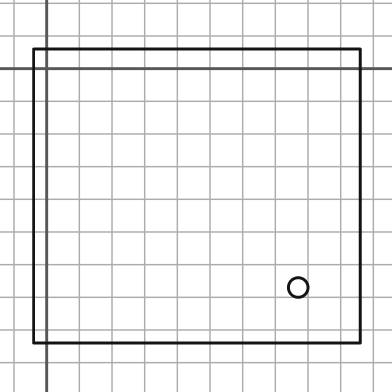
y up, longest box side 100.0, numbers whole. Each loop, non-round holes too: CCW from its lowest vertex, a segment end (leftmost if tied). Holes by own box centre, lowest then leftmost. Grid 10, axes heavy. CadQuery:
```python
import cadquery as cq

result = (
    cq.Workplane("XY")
    .moveTo(-4.0, -84.0)
    .lineTo(96.0, -84.0)
    .lineTo(96.0, 6.0)
    .lineTo(-4.0, 6.0)
    .close()
    .moveTo(77.0, -67.0)
    .circle(3.0)
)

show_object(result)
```